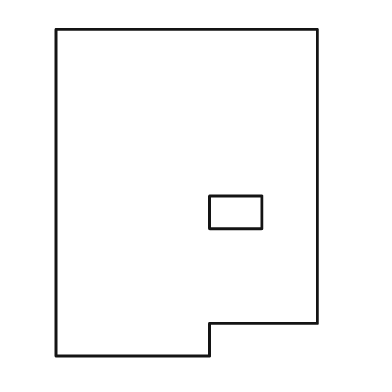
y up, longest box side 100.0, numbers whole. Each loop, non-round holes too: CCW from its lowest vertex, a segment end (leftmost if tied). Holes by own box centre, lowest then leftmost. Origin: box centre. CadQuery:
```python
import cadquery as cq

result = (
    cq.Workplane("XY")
    .moveTo(-40.0, -50.0)
    .lineTo(7.0, -50.0)
    .lineTo(7.0, -40.0)
    .lineTo(40.0, -40.0)
    .lineTo(40.0, 50.0)
    .lineTo(-40.0, 50.0)
    .close()
    .moveTo(7.0, -11.0)
    .lineTo(23.0, -11.0)
    .lineTo(23.0, -1.0)
    .lineTo(7.0, -1.0)
    .close()
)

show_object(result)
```